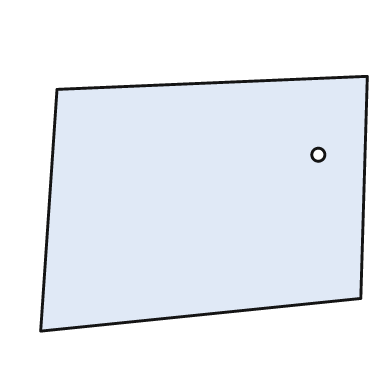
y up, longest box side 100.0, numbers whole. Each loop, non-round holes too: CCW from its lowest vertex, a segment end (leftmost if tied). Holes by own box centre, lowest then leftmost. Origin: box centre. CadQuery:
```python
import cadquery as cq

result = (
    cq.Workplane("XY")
    .moveTo(-50.0, -39.0)
    .lineTo(48.0, -29.0)
    .lineTo(50.0, 39.0)
    .lineTo(-45.0, 35.0)
    .close()
    .moveTo(35.0, 15.0)
    .circle(2.0)
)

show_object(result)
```